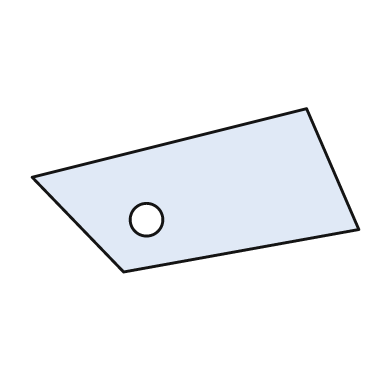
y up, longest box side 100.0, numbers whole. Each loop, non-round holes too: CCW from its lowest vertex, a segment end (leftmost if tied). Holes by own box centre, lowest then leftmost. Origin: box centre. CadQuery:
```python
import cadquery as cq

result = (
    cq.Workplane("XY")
    .moveTo(-22.0, -25.0)
    .lineTo(50.0, -12.0)
    .lineTo(34.0, 25.0)
    .lineTo(-50.0, 4.0)
    .close()
    .moveTo(-15.0, -9.0)
    .circle(5.0)
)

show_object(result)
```